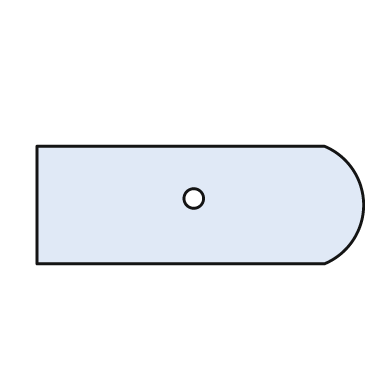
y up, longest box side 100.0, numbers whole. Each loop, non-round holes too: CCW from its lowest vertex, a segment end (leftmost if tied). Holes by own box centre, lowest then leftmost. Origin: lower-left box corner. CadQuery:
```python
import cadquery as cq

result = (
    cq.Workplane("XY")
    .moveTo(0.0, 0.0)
    .lineTo(88.0, 0.0)
    .threePointArc((100.0, 18.0), (88.0, 36.0))
    .lineTo(0.0, 36.0)
    .close()
    .moveTo(48.0, 20.0)
    .circle(3.0)
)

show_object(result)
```